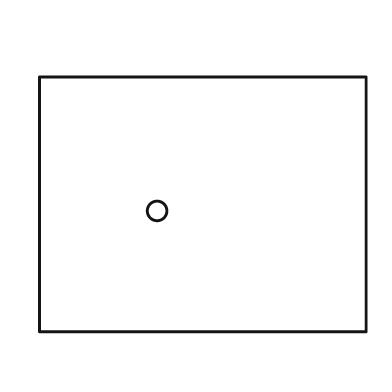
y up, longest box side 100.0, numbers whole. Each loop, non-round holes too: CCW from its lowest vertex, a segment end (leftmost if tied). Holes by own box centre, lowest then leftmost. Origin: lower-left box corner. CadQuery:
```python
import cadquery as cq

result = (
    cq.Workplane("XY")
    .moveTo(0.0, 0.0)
    .lineTo(100.0, 0.0)
    .lineTo(100.0, 78.0)
    .lineTo(0.0, 78.0)
    .close()
    .moveTo(36.0, 37.0)
    .circle(3.0)
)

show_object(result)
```